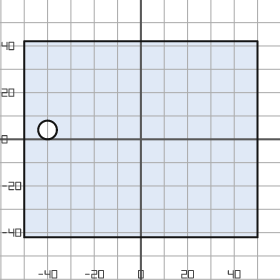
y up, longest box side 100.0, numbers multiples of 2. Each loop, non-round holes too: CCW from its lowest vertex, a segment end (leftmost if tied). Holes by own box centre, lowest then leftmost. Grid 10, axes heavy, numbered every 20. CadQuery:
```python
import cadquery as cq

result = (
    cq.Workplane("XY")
    .moveTo(-50.0, -42.0)
    .lineTo(50.0, -42.0)
    .lineTo(50.0, 42.0)
    .lineTo(-50.0, 42.0)
    .close()
    .moveTo(-40.0, 4.0)
    .circle(4.0)
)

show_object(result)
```